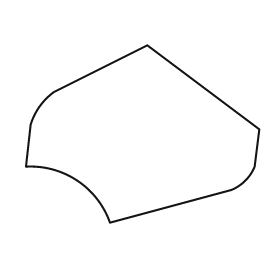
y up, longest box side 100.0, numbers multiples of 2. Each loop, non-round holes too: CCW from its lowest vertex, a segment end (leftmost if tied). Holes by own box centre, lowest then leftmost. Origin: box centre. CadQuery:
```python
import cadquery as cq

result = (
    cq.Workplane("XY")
    .moveTo(-14.0, -38.0)
    .lineTo(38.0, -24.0)
    .threePointArc((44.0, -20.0), (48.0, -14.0))
    .lineTo(50.0, 2.0)
    .lineTo(2.0, 38.0)
    .lineTo(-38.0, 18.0)
    .threePointArc((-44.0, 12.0), (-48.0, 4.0))
    .lineTo(-50.0, -14.0)
    .threePointArc((-28.0, -20.0), (-14.0, -38.0))
    .close()
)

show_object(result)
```